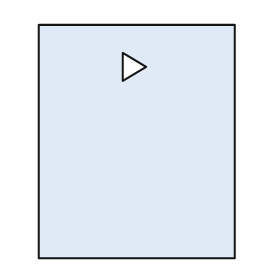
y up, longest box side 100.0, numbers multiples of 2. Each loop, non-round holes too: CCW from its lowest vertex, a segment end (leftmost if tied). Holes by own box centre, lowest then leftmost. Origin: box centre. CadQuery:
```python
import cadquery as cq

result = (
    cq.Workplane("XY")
    .moveTo(-42.0, -50.0)
    .lineTo(42.0, -50.0)
    .lineTo(42.0, 50.0)
    .lineTo(-42.0, 50.0)
    .close()
    .moveTo(-6.0, 26.0)
    .lineTo(4.0, 32.0)
    .lineTo(-6.0, 38.0)
    .close()
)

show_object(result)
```